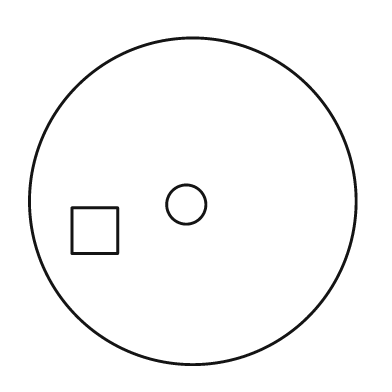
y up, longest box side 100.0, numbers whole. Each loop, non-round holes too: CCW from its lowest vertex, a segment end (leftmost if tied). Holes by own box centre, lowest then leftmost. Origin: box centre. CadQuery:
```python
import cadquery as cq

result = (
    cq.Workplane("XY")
    .moveTo(0.0, 0.0)
    .circle(50.0)
    .moveTo(-37.0, -16.0)
    .lineTo(-23.0, -16.0)
    .lineTo(-23.0, -2.0)
    .lineTo(-37.0, -2.0)
    .close()
    .moveTo(-2.0, -1.0)
    .circle(6.0)
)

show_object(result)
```